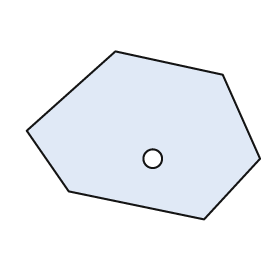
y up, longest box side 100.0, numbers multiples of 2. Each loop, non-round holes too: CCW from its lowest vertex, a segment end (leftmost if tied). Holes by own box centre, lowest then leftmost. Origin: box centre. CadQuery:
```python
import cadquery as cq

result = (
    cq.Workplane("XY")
    .moveTo(26.0, -36.0)
    .lineTo(50.0, -10.0)
    .lineTo(34.0, 26.0)
    .lineTo(-12.0, 36.0)
    .lineTo(-50.0, 2.0)
    .lineTo(-32.0, -24.0)
    .close()
    .moveTo(4.0, -10.0)
    .circle(4.0)
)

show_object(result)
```